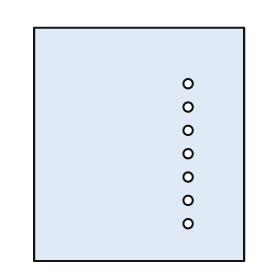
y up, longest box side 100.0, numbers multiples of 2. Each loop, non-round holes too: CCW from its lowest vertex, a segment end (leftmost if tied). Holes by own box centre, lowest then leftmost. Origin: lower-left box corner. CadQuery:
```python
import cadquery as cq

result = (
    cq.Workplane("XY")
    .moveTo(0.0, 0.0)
    .lineTo(90.0, 0.0)
    .lineTo(90.0, 100.0)
    .lineTo(0.0, 100.0)
    .close()
    .moveTo(66.0, 16.0)
    .circle(2.0)
    .moveTo(66.0, 26.0)
    .circle(2.0)
    .moveTo(66.0, 36.0)
    .circle(2.0)
    .moveTo(66.0, 46.0)
    .circle(2.0)
    .moveTo(66.0, 56.0)
    .circle(2.0)
    .moveTo(66.0, 66.0)
    .circle(2.0)
    .moveTo(66.0, 76.0)
    .circle(2.0)
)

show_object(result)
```